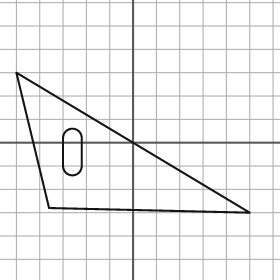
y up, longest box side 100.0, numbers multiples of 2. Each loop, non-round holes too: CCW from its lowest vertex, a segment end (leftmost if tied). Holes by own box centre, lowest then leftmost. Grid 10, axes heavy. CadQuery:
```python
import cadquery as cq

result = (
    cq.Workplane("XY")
    .moveTo(50.0, -30.0)
    .lineTo(-50.0, 30.0)
    .lineTo(-36.0, -28.0)
    .close()
    .moveTo(-30.0, -10.0)
    .threePointArc((-26.0, -14.0), (-22.0, -10.0))
    .lineTo(-22.0, 2.0)
    .threePointArc((-26.0, 6.0), (-30.0, 2.0))
    .close()
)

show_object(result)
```